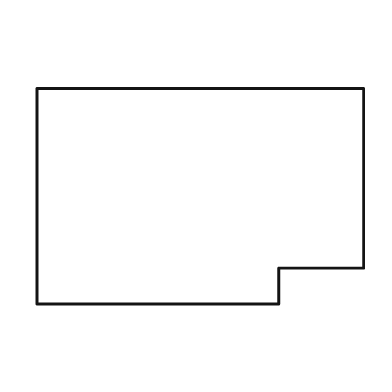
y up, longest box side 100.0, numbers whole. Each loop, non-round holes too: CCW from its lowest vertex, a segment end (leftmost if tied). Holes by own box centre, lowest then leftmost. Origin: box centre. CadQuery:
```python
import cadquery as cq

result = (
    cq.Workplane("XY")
    .moveTo(-50.0, -33.0)
    .lineTo(24.0, -33.0)
    .lineTo(24.0, -22.0)
    .lineTo(50.0, -22.0)
    .lineTo(50.0, 33.0)
    .lineTo(-50.0, 33.0)
    .close()
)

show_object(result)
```